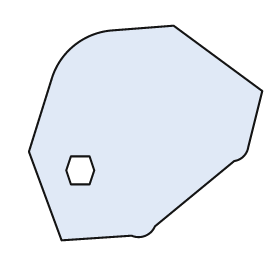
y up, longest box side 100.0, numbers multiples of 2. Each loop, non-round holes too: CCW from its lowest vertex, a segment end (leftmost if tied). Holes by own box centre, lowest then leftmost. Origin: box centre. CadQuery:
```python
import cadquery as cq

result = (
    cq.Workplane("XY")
    .moveTo(-36.0, -46.0)
    .lineTo(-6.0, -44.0)
    .threePointArc((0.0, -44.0), (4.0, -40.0))
    .lineTo(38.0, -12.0)
    .threePointArc((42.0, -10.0), (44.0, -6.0))
    .lineTo(50.0, 18.0)
    .lineTo(12.0, 46.0)
    .lineTo(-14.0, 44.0)
    .threePointArc((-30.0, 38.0), (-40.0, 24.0))
    .lineTo(-50.0, -8.0)
    .close()
    .moveTo(-32.0, -22.0)
    .lineTo(-24.0, -22.0)
    .lineTo(-22.0, -16.0)
    .lineTo(-24.0, -10.0)
    .lineTo(-32.0, -10.0)
    .lineTo(-34.0, -16.0)
    .close()
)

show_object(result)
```